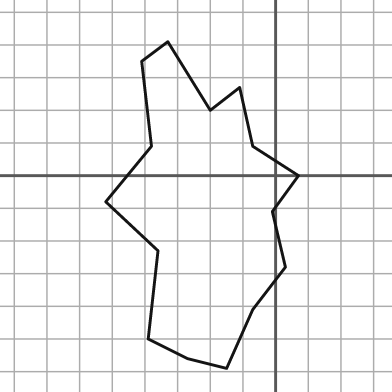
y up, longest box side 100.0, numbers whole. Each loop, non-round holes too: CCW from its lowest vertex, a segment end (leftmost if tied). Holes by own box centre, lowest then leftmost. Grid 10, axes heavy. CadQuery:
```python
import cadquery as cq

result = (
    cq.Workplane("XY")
    .moveTo(-15.0, -59.0)
    .lineTo(-7.0, -41.0)
    .lineTo(3.0, -28.0)
    .lineTo(-1.0, -11.0)
    .lineTo(7.0, 0.0)
    .lineTo(-7.0, 9.0)
    .lineTo(-11.0, 27.0)
    .lineTo(-20.0, 20.0)
    .lineTo(-33.0, 41.0)
    .lineTo(-41.0, 35.0)
    .lineTo(-38.0, 9.0)
    .lineTo(-52.0, -8.0)
    .lineTo(-36.0, -23.0)
    .lineTo(-39.0, -50.0)
    .lineTo(-27.0, -56.0)
    .close()
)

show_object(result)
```